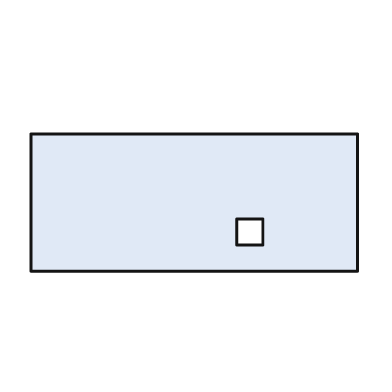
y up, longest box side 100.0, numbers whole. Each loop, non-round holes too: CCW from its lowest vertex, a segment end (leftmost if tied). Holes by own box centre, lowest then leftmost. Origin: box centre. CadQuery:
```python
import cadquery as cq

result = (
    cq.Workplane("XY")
    .moveTo(-50.0, -21.0)
    .lineTo(50.0, -21.0)
    .lineTo(50.0, 21.0)
    .lineTo(-50.0, 21.0)
    .close()
    .moveTo(13.0, -13.0)
    .lineTo(21.0, -13.0)
    .lineTo(21.0, -5.0)
    .lineTo(13.0, -5.0)
    .close()
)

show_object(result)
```